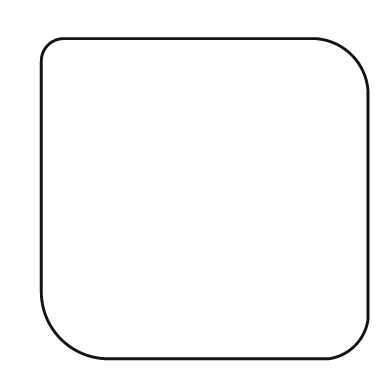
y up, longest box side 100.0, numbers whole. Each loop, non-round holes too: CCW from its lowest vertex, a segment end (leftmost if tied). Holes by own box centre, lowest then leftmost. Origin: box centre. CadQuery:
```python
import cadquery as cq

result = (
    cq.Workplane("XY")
    .moveTo(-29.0, -49.0)
    .lineTo(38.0, -49.0)
    .threePointArc((46.0, -45.0), (50.0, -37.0))
    .lineTo(50.0, 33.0)
    .threePointArc((45.0, 44.0), (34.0, 49.0))
    .lineTo(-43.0, 49.0)
    .threePointArc((-48.0, 47.0), (-50.0, 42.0))
    .lineTo(-50.0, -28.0)
    .threePointArc((-44.0, -43.0), (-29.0, -49.0))
    .close()
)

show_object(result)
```